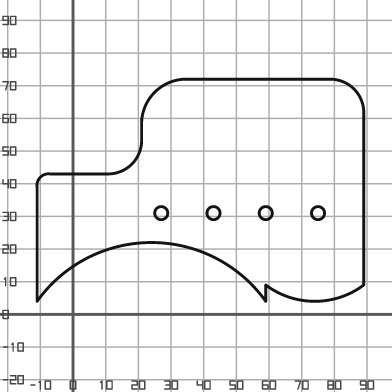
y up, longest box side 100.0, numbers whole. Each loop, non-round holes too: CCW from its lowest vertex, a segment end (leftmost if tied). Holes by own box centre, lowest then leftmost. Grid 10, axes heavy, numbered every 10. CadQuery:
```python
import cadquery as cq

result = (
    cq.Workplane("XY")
    .moveTo(-11.0, 4.0)
    .threePointArc((24.0, 22.0), (59.0, 4.0))
    .lineTo(59.0, 9.0)
    .threePointArc((74.0, 4.0), (89.0, 9.0))
    .lineTo(89.0, 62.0)
    .threePointArc((86.0, 69.0), (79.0, 72.0))
    .lineTo(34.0, 72.0)
    .threePointArc((25.0, 68.0), (21.0, 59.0))
    .lineTo(21.0, 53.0)
    .threePointArc((18.0, 46.0), (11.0, 43.0))
    .lineTo(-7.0, 43.0)
    .threePointArc((-10.0, 42.0), (-11.0, 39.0))
    .close()
    .moveTo(27.0, 31.0)
    .circle(2.0)
    .moveTo(43.0, 31.0)
    .circle(2.0)
    .moveTo(59.0, 31.0)
    .circle(2.0)
    .moveTo(75.0, 31.0)
    .circle(2.0)
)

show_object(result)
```